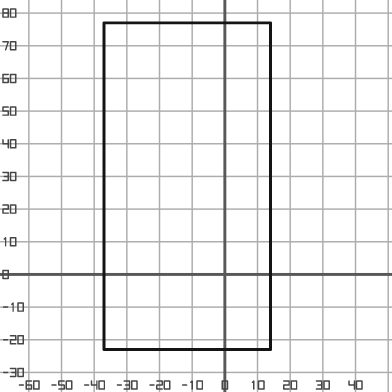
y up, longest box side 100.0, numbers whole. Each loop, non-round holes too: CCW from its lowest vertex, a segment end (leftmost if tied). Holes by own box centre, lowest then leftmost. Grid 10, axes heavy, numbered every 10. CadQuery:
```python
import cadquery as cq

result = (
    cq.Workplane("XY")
    .moveTo(-37.0, -23.0)
    .lineTo(14.0, -23.0)
    .lineTo(14.0, 77.0)
    .lineTo(-37.0, 77.0)
    .close()
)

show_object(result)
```